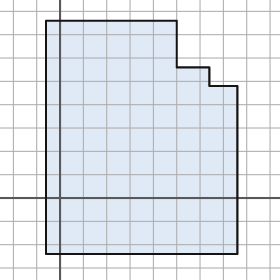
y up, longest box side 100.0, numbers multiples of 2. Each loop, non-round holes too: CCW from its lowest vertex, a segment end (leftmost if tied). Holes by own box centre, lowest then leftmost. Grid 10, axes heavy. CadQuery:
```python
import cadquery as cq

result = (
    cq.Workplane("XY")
    .moveTo(-6.0, -24.0)
    .lineTo(76.0, -24.0)
    .lineTo(76.0, 48.0)
    .lineTo(64.0, 48.0)
    .lineTo(64.0, 56.0)
    .lineTo(50.0, 56.0)
    .lineTo(50.0, 76.0)
    .lineTo(-6.0, 76.0)
    .close()
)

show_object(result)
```